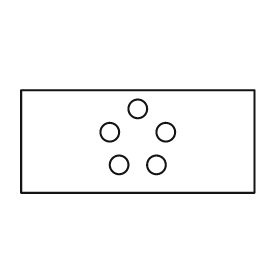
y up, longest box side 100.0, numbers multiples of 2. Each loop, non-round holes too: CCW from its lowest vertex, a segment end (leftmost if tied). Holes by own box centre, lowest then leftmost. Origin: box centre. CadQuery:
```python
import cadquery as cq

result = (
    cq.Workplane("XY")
    .moveTo(-50.0, -22.0)
    .lineTo(50.0, -22.0)
    .lineTo(50.0, 22.0)
    .lineTo(-50.0, 22.0)
    .close()
    .moveTo(-8.0, -10.0)
    .circle(4.0)
    .moveTo(8.0, -10.0)
    .circle(4.0)
    .moveTo(-12.0, 4.0)
    .circle(4.0)
    .moveTo(12.0, 4.0)
    .circle(4.0)
    .moveTo(0.0, 14.0)
    .circle(4.0)
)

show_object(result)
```